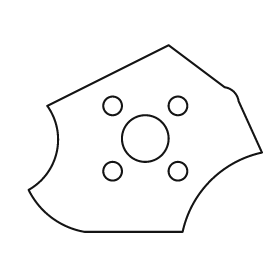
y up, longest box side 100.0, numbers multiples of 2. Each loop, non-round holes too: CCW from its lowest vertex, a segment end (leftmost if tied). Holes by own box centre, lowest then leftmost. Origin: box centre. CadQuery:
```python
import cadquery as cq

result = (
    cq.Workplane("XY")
    .moveTo(-26.0, -40.0)
    .lineTo(16.0, -40.0)
    .threePointArc((28.0, -18.0), (50.0, -6.0))
    .lineTo(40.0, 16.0)
    .threePointArc((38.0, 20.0), (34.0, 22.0))
    .lineTo(10.0, 40.0)
    .lineTo(-42.0, 14.0)
    .threePointArc((-38.0, -6.0), (-50.0, -22.0))
    .threePointArc((-40.0, -34.0), (-26.0, -40.0))
    .close()
    .moveTo(-14.0, -14.0)
    .circle(4.0)
    .moveTo(14.0, -14.0)
    .circle(4.0)
    .moveTo(0.0, 0.0)
    .circle(10.0)
    .moveTo(-14.0, 14.0)
    .circle(4.0)
    .moveTo(14.0, 14.0)
    .circle(4.0)
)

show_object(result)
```